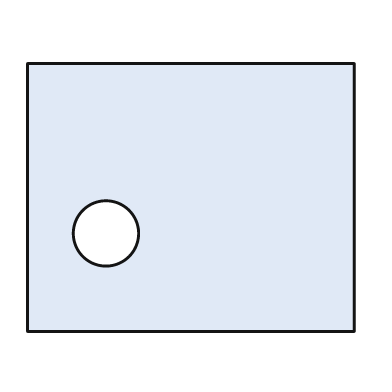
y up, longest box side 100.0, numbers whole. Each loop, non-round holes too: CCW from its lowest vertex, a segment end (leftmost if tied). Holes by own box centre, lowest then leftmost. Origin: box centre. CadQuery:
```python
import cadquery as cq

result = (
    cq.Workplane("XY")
    .moveTo(-50.0, -41.0)
    .lineTo(50.0, -41.0)
    .lineTo(50.0, 41.0)
    .lineTo(-50.0, 41.0)
    .close()
    .moveTo(-26.0, -11.0)
    .circle(10.0)
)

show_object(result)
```